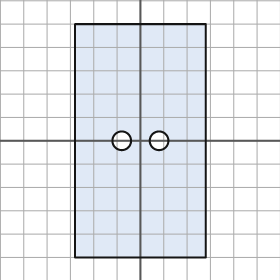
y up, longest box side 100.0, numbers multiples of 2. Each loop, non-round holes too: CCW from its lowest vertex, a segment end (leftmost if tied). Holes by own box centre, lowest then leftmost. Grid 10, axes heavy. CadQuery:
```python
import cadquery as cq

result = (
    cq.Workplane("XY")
    .moveTo(-28.0, -50.0)
    .lineTo(28.0, -50.0)
    .lineTo(28.0, 50.0)
    .lineTo(-28.0, 50.0)
    .close()
    .moveTo(-8.0, 0.0)
    .circle(4.0)
    .moveTo(8.0, 0.0)
    .circle(4.0)
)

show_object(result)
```